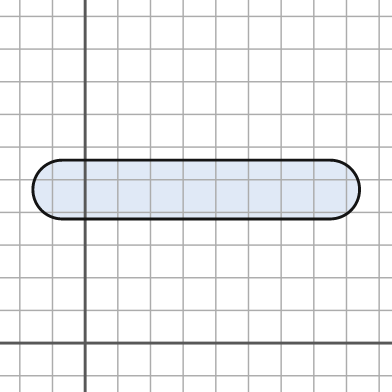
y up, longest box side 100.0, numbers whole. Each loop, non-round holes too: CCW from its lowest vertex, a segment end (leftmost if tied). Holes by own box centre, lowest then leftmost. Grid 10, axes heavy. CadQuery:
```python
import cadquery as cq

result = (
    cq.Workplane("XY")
    .moveTo(-7.0, 38.0)
    .lineTo(75.0, 38.0)
    .threePointArc((84.0, 47.0), (75.0, 56.0))
    .lineTo(-7.0, 56.0)
    .threePointArc((-16.0, 47.0), (-7.0, 38.0))
    .close()
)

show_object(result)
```